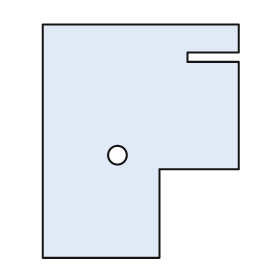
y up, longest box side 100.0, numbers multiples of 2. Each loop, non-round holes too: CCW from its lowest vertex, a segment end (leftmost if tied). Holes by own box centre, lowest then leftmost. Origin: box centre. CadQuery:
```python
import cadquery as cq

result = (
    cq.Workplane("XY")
    .moveTo(-42.0, -50.0)
    .lineTo(8.0, -50.0)
    .lineTo(8.0, -12.0)
    .lineTo(42.0, -12.0)
    .lineTo(42.0, 34.0)
    .lineTo(20.0, 34.0)
    .lineTo(20.0, 38.0)
    .lineTo(42.0, 38.0)
    .lineTo(42.0, 50.0)
    .lineTo(-42.0, 50.0)
    .close()
    .moveTo(-10.0, -6.0)
    .circle(4.0)
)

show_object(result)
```